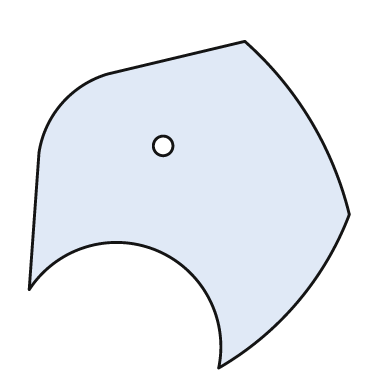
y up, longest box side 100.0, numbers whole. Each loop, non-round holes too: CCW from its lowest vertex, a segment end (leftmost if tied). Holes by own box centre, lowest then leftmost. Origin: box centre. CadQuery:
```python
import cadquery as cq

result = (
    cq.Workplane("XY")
    .moveTo(9.0, -50.0)
    .threePointArc((33.0, -30.0), (49.0, -3.0))
    .threePointArc((37.0, 26.0), (17.0, 50.0))
    .lineTo(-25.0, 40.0)
    .threePointArc((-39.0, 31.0), (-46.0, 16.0))
    .lineTo(-49.0, -26.0)
    .threePointArc((-10.0, -14.0), (9.0, -50.0))
    .close()
    .moveTo(-8.0, 18.0)
    .circle(3.0)
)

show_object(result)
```